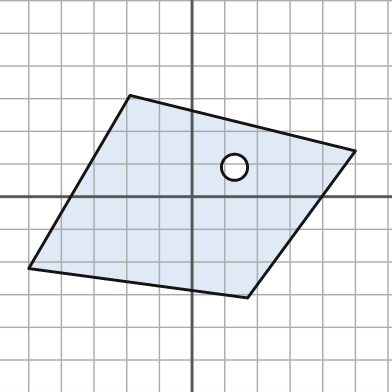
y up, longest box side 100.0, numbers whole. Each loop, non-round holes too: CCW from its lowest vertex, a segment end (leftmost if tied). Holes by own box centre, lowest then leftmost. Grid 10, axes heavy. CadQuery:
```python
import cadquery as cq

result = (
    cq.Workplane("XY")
    .moveTo(17.0, -31.0)
    .lineTo(50.0, 14.0)
    .lineTo(-19.0, 31.0)
    .lineTo(-50.0, -22.0)
    .close()
    .moveTo(13.0, 9.0)
    .circle(4.0)
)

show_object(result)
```